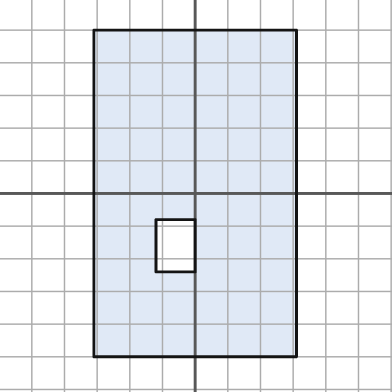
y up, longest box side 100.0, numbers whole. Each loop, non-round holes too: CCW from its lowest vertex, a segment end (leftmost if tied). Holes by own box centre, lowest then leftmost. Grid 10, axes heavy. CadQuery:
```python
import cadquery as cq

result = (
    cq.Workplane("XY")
    .moveTo(-31.0, -50.0)
    .lineTo(31.0, -50.0)
    .lineTo(31.0, 50.0)
    .lineTo(-31.0, 50.0)
    .close()
    .moveTo(-12.0, -24.0)
    .lineTo(0.0, -24.0)
    .lineTo(0.0, -8.0)
    .lineTo(-12.0, -8.0)
    .close()
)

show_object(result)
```